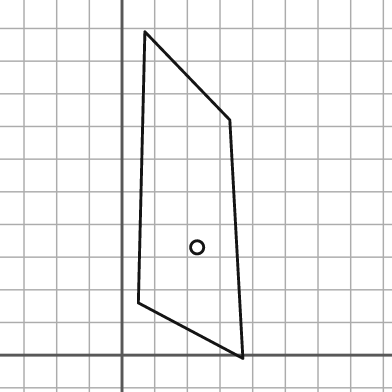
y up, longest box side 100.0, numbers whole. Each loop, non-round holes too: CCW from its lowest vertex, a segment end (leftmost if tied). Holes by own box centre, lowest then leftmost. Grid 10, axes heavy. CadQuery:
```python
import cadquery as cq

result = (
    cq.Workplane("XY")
    .moveTo(37.0, -1.0)
    .lineTo(33.0, 72.0)
    .lineTo(7.0, 99.0)
    .lineTo(5.0, 16.0)
    .close()
    .moveTo(23.0, 33.0)
    .circle(2.0)
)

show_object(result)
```